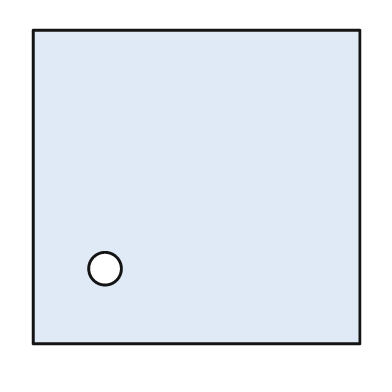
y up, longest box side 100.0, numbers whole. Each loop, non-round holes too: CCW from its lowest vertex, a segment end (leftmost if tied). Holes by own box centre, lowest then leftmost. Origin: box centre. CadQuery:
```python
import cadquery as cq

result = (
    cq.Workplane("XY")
    .moveTo(-50.0, -48.0)
    .lineTo(50.0, -48.0)
    .lineTo(50.0, 48.0)
    .lineTo(-50.0, 48.0)
    .close()
    .moveTo(-28.0, -25.0)
    .circle(5.0)
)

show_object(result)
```